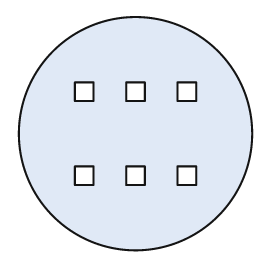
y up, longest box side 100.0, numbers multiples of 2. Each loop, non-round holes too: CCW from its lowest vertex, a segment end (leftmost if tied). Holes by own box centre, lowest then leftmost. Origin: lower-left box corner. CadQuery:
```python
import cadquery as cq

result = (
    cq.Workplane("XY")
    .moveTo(50.0, 50.0)
    .circle(50.0)
    .moveTo(24.0, 28.0)
    .lineTo(32.0, 28.0)
    .lineTo(32.0, 36.0)
    .lineTo(24.0, 36.0)
    .close()
    .moveTo(46.0, 28.0)
    .lineTo(54.0, 28.0)
    .lineTo(54.0, 36.0)
    .lineTo(46.0, 36.0)
    .close()
    .moveTo(68.0, 28.0)
    .lineTo(76.0, 28.0)
    .lineTo(76.0, 36.0)
    .lineTo(68.0, 36.0)
    .close()
    .moveTo(24.0, 64.0)
    .lineTo(32.0, 64.0)
    .lineTo(32.0, 72.0)
    .lineTo(24.0, 72.0)
    .close()
    .moveTo(46.0, 64.0)
    .lineTo(54.0, 64.0)
    .lineTo(54.0, 72.0)
    .lineTo(46.0, 72.0)
    .close()
    .moveTo(68.0, 64.0)
    .lineTo(76.0, 64.0)
    .lineTo(76.0, 72.0)
    .lineTo(68.0, 72.0)
    .close()
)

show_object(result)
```